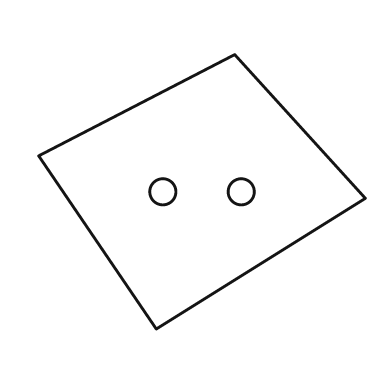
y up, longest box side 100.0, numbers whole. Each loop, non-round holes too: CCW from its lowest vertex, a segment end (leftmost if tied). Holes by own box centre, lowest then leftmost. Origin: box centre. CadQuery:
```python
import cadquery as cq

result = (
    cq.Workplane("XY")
    .moveTo(-14.0, -42.0)
    .lineTo(50.0, -2.0)
    .lineTo(10.0, 42.0)
    .lineTo(-50.0, 11.0)
    .close()
    .moveTo(-12.0, 0.0)
    .circle(4.0)
    .moveTo(12.0, 0.0)
    .circle(4.0)
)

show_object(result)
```